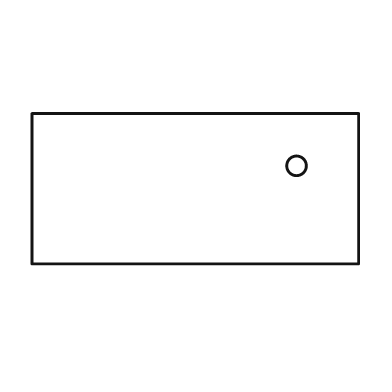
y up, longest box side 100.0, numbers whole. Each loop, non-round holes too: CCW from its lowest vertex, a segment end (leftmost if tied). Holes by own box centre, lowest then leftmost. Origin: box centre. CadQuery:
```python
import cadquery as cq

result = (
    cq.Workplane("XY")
    .moveTo(-50.0, -23.0)
    .lineTo(50.0, -23.0)
    .lineTo(50.0, 23.0)
    .lineTo(-50.0, 23.0)
    .close()
    .moveTo(31.0, 7.0)
    .circle(3.0)
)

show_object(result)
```